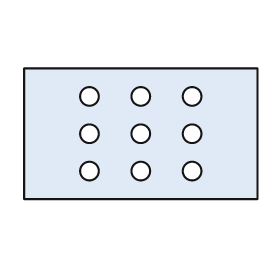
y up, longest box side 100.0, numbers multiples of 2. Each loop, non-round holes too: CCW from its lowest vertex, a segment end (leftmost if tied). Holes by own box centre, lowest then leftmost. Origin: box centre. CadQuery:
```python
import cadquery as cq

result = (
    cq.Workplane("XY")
    .moveTo(-50.0, -28.0)
    .lineTo(50.0, -28.0)
    .lineTo(50.0, 28.0)
    .lineTo(-50.0, 28.0)
    .close()
    .moveTo(-22.0, -16.0)
    .circle(4.0)
    .moveTo(0.0, -16.0)
    .circle(4.0)
    .moveTo(22.0, -16.0)
    .circle(4.0)
    .moveTo(-22.0, 0.0)
    .circle(4.0)
    .moveTo(0.0, 0.0)
    .circle(4.0)
    .moveTo(22.0, 0.0)
    .circle(4.0)
    .moveTo(-22.0, 16.0)
    .circle(4.0)
    .moveTo(0.0, 16.0)
    .circle(4.0)
    .moveTo(22.0, 16.0)
    .circle(4.0)
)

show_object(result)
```